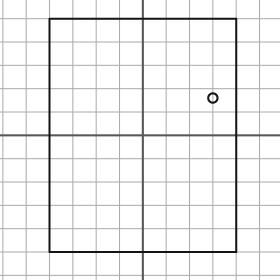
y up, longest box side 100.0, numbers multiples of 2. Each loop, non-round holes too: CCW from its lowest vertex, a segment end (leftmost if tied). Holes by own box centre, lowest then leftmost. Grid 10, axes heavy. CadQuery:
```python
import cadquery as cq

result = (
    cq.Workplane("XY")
    .moveTo(-40.0, -50.0)
    .lineTo(40.0, -50.0)
    .lineTo(40.0, 50.0)
    .lineTo(-40.0, 50.0)
    .close()
    .moveTo(30.0, 16.0)
    .circle(2.0)
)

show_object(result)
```